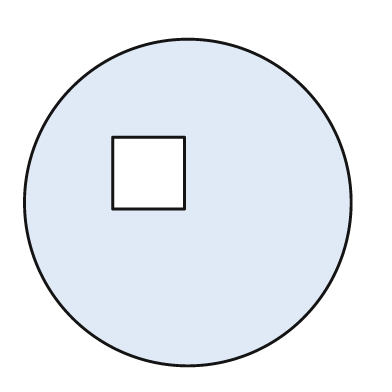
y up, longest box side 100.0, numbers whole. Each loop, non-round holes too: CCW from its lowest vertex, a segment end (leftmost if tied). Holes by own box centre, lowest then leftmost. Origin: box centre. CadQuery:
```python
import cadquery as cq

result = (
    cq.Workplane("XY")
    .moveTo(0.0, 0.0)
    .circle(50.0)
    .moveTo(-23.0, -2.0)
    .lineTo(-1.0, -2.0)
    .lineTo(-1.0, 20.0)
    .lineTo(-23.0, 20.0)
    .close()
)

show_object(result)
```